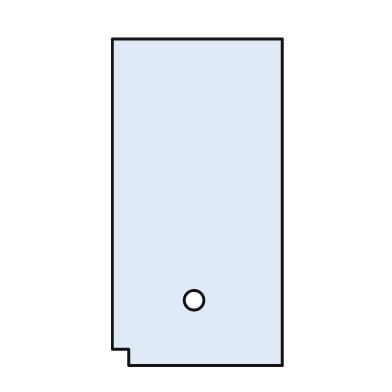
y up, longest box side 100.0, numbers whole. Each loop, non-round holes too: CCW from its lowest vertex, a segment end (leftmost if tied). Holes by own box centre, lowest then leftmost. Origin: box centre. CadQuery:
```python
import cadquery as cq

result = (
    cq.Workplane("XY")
    .moveTo(-21.0, -50.0)
    .lineTo(26.0, -50.0)
    .lineTo(26.0, 50.0)
    .lineTo(-26.0, 50.0)
    .lineTo(-26.0, -45.0)
    .lineTo(-21.0, -45.0)
    .close()
    .moveTo(-1.0, -30.0)
    .circle(3.0)
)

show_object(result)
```